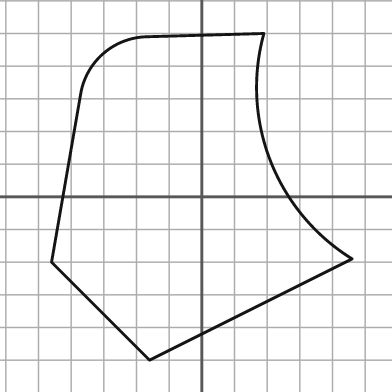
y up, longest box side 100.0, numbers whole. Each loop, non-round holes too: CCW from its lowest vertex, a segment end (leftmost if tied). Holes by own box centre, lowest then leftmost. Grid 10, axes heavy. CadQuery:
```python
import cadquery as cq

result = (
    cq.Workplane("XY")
    .moveTo(-16.0, -50.0)
    .lineTo(46.0, -19.0)
    .threePointArc((21.0, 11.0), (19.0, 50.0))
    .lineTo(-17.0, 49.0)
    .threePointArc((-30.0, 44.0), (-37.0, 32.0))
    .lineTo(-46.0, -20.0)
    .close()
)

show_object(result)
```